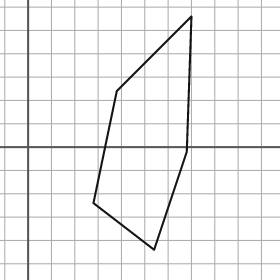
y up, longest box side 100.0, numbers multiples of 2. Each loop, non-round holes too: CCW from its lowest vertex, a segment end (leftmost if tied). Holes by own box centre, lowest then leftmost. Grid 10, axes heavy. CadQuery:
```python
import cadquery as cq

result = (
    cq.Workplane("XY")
    .moveTo(54.0, -44.0)
    .lineTo(68.0, -2.0)
    .lineTo(70.0, 56.0)
    .lineTo(38.0, 24.0)
    .lineTo(28.0, -24.0)
    .close()
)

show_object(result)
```